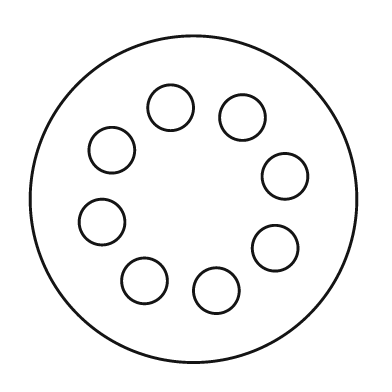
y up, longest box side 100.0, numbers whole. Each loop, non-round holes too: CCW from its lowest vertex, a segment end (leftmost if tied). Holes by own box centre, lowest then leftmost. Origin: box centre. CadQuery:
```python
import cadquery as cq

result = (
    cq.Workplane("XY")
    .moveTo(0.0, 0.0)
    .circle(50.0)
    .moveTo(7.0, -28.0)
    .circle(7.0)
    .moveTo(-15.0, -25.0)
    .circle(7.0)
    .moveTo(25.0, -15.0)
    .circle(7.0)
    .moveTo(-28.0, -7.0)
    .circle(7.0)
    .moveTo(28.0, 7.0)
    .circle(7.0)
    .moveTo(-25.0, 15.0)
    .circle(7.0)
    .moveTo(15.0, 25.0)
    .circle(7.0)
    .moveTo(-7.0, 28.0)
    .circle(7.0)
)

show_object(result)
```